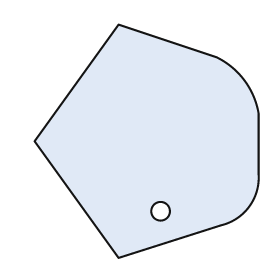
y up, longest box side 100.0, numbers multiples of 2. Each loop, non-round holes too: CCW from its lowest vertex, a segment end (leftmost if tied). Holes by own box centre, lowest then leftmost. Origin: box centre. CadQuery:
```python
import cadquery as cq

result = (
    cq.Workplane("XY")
    .moveTo(-12.0, -50.0)
    .lineTo(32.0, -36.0)
    .threePointArc((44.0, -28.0), (48.0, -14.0))
    .lineTo(48.0, 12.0)
    .threePointArc((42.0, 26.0), (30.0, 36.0))
    .lineTo(-12.0, 50.0)
    .lineTo(-48.0, 0.0)
    .close()
    .moveTo(6.0, -30.0)
    .circle(4.0)
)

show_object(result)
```